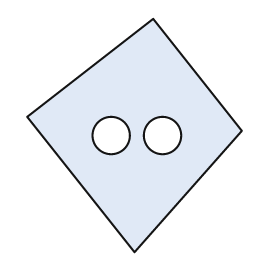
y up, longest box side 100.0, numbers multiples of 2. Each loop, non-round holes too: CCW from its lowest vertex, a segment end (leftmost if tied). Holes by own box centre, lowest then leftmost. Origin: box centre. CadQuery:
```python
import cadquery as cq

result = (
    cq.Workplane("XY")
    .moveTo(0.0, -50.0)
    .lineTo(46.0, 2.0)
    .lineTo(8.0, 50.0)
    .lineTo(-46.0, 8.0)
    .close()
    .moveTo(-10.0, 0.0)
    .circle(8.0)
    .moveTo(12.0, 0.0)
    .circle(8.0)
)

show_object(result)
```